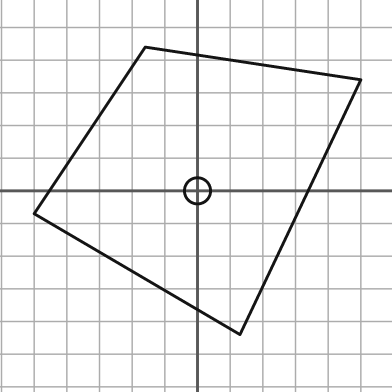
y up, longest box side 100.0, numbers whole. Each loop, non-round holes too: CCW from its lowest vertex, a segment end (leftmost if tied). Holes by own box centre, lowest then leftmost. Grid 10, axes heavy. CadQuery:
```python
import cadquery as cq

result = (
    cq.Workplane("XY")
    .moveTo(13.0, -44.0)
    .lineTo(50.0, 34.0)
    .lineTo(-16.0, 44.0)
    .lineTo(-50.0, -7.0)
    .close()
    .moveTo(0.0, 0.0)
    .circle(4.0)
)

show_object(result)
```